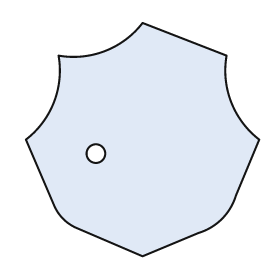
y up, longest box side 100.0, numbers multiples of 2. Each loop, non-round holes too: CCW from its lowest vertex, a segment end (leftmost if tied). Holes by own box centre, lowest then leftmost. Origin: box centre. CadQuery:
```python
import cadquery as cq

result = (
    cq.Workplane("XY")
    .moveTo(0.0, -50.0)
    .lineTo(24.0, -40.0)
    .threePointArc((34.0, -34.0), (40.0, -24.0))
    .lineTo(50.0, 0.0)
    .threePointArc((38.0, 16.0), (36.0, 36.0))
    .lineTo(0.0, 50.0)
    .threePointArc((-16.0, 38.0), (-36.0, 36.0))
    .threePointArc((-38.0, 16.0), (-50.0, 0.0))
    .lineTo(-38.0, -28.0)
    .threePointArc((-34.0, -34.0), (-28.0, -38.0))
    .close()
    .moveTo(-20.0, -6.0)
    .circle(4.0)
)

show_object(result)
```